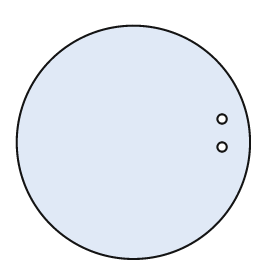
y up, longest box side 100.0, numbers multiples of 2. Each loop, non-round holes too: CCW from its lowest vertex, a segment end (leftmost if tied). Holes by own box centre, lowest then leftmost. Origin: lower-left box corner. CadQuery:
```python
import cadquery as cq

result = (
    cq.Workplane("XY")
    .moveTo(50.0, 50.0)
    .circle(50.0)
    .moveTo(88.0, 48.0)
    .circle(2.0)
    .moveTo(88.0, 60.0)
    .circle(2.0)
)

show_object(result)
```